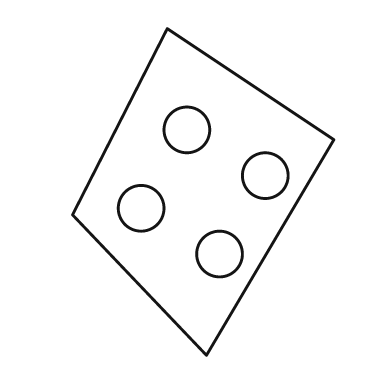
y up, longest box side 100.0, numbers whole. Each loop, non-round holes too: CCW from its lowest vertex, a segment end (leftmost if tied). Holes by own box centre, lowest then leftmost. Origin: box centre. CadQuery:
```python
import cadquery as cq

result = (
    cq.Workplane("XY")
    .moveTo(1.0, -50.0)
    .lineTo(40.0, 16.0)
    .lineTo(-11.0, 50.0)
    .lineTo(-40.0, -7.0)
    .close()
    .moveTo(5.0, -19.0)
    .circle(7.0)
    .moveTo(-19.0, -5.0)
    .circle(7.0)
    .moveTo(19.0, 5.0)
    .circle(7.0)
    .moveTo(-5.0, 19.0)
    .circle(7.0)
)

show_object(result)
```